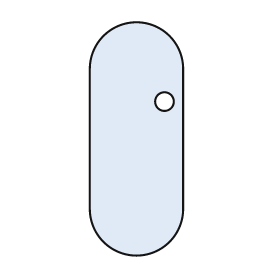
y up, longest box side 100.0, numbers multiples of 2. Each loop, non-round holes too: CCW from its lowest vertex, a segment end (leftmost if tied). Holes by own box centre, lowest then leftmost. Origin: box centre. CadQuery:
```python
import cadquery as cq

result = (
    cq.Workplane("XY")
    .moveTo(-20.0, -30.0)
    .threePointArc((0.0, -50.0), (20.0, -30.0))
    .lineTo(20.0, 30.0)
    .threePointArc((0.0, 50.0), (-20.0, 30.0))
    .close()
    .moveTo(12.0, 16.0)
    .circle(4.0)
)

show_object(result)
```